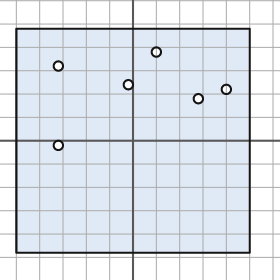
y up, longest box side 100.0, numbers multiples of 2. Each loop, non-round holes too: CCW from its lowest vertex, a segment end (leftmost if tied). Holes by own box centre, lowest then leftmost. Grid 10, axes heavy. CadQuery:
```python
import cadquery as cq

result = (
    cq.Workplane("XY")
    .moveTo(-50.0, -48.0)
    .lineTo(50.0, -48.0)
    .lineTo(50.0, 48.0)
    .lineTo(-50.0, 48.0)
    .close()
    .moveTo(-32.0, -2.0)
    .circle(2.0)
    .moveTo(28.0, 18.0)
    .circle(2.0)
    .moveTo(40.0, 22.0)
    .circle(2.0)
    .moveTo(-2.0, 24.0)
    .circle(2.0)
    .moveTo(-32.0, 32.0)
    .circle(2.0)
    .moveTo(10.0, 38.0)
    .circle(2.0)
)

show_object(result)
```